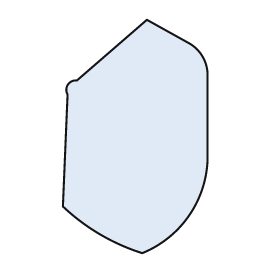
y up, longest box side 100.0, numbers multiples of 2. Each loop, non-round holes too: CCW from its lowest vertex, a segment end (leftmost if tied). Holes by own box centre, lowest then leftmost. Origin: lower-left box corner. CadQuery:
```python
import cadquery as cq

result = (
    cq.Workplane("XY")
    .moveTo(34.0, 0.0)
    .threePointArc((54.0, 16.0), (62.0, 40.0))
    .lineTo(62.0, 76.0)
    .threePointArc((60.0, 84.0), (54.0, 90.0))
    .lineTo(36.0, 100.0)
    .lineTo(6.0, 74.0)
    .threePointArc((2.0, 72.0), (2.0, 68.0))
    .lineTo(0.0, 20.0)
    .threePointArc((16.0, 8.0), (34.0, 0.0))
    .close()
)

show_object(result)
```